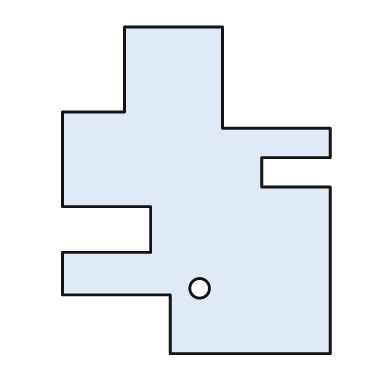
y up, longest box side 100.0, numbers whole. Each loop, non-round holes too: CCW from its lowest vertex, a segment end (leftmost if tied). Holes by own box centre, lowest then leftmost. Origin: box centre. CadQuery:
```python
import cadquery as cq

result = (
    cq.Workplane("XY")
    .moveTo(-8.0, -50.0)
    .lineTo(41.0, -50.0)
    .lineTo(41.0, 1.0)
    .lineTo(20.0, 1.0)
    .lineTo(20.0, 10.0)
    .lineTo(41.0, 10.0)
    .lineTo(41.0, 19.0)
    .lineTo(8.0, 19.0)
    .lineTo(8.0, 50.0)
    .lineTo(-22.0, 50.0)
    .lineTo(-22.0, 24.0)
    .lineTo(-41.0, 24.0)
    .lineTo(-41.0, -5.0)
    .lineTo(-14.0, -5.0)
    .lineTo(-14.0, -19.0)
    .lineTo(-41.0, -19.0)
    .lineTo(-41.0, -32.0)
    .lineTo(-8.0, -32.0)
    .close()
    .moveTo(1.0, -30.0)
    .circle(3.0)
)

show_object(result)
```